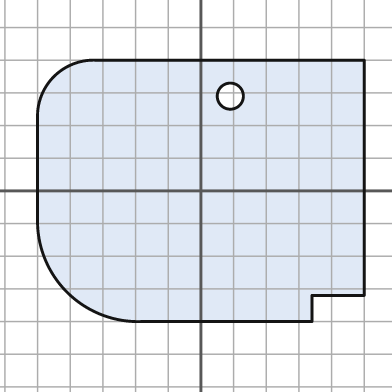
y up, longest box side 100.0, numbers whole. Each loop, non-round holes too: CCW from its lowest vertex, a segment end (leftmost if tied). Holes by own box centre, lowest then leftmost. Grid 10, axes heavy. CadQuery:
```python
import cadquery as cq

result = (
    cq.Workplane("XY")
    .moveTo(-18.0, -40.0)
    .lineTo(34.0, -40.0)
    .lineTo(34.0, -32.0)
    .lineTo(50.0, -32.0)
    .lineTo(50.0, 40.0)
    .lineTo(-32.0, 40.0)
    .threePointArc((-45.0, 35.0), (-50.0, 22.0))
    .lineTo(-50.0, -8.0)
    .threePointArc((-41.0, -31.0), (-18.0, -40.0))
    .close()
    .moveTo(9.0, 29.0)
    .circle(4.0)
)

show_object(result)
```